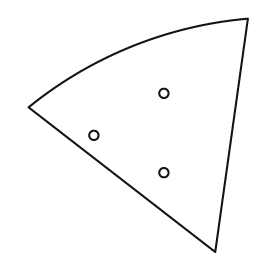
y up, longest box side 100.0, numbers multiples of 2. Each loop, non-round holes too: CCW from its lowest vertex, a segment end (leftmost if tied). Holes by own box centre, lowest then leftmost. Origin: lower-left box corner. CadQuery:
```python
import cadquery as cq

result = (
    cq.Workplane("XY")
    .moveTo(80.0, 0.0)
    .lineTo(94.0, 100.0)
    .threePointArc((44.0, 88.0), (0.0, 62.0))
    .close()
    .moveTo(58.0, 34.0)
    .circle(2.0)
    .moveTo(28.0, 50.0)
    .circle(2.0)
    .moveTo(58.0, 68.0)
    .circle(2.0)
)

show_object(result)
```